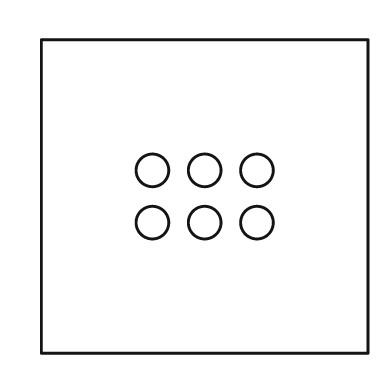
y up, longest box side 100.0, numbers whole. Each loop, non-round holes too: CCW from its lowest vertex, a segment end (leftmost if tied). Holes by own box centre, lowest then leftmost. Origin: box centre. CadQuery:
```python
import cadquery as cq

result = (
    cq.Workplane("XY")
    .moveTo(-50.0, -48.0)
    .lineTo(50.0, -48.0)
    .lineTo(50.0, 48.0)
    .lineTo(-50.0, 48.0)
    .close()
    .moveTo(-16.0, -8.0)
    .circle(5.0)
    .moveTo(0.0, -8.0)
    .circle(5.0)
    .moveTo(16.0, -8.0)
    .circle(5.0)
    .moveTo(-16.0, 8.0)
    .circle(5.0)
    .moveTo(0.0, 8.0)
    .circle(5.0)
    .moveTo(16.0, 8.0)
    .circle(5.0)
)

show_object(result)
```